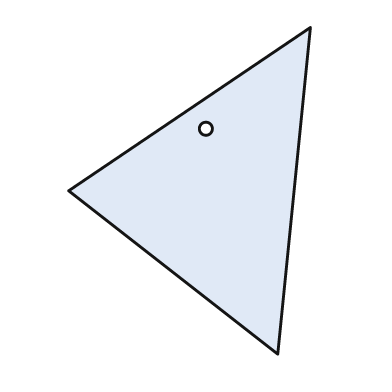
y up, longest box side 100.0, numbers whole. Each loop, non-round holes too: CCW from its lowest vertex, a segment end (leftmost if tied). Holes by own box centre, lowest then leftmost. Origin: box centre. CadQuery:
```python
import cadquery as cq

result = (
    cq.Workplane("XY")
    .moveTo(27.0, -50.0)
    .lineTo(37.0, 50.0)
    .lineTo(-37.0, 0.0)
    .close()
    .moveTo(5.0, 19.0)
    .circle(2.0)
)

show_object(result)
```